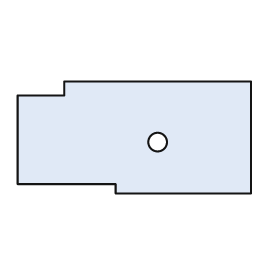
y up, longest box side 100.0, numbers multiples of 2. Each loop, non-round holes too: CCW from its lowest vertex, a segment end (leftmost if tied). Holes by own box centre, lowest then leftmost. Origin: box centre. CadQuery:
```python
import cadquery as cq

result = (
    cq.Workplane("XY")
    .moveTo(-8.0, -24.0)
    .lineTo(50.0, -24.0)
    .lineTo(50.0, 24.0)
    .lineTo(-30.0, 24.0)
    .lineTo(-30.0, 18.0)
    .lineTo(-50.0, 18.0)
    .lineTo(-50.0, -20.0)
    .lineTo(-8.0, -20.0)
    .close()
    .moveTo(10.0, -2.0)
    .circle(4.0)
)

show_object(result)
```